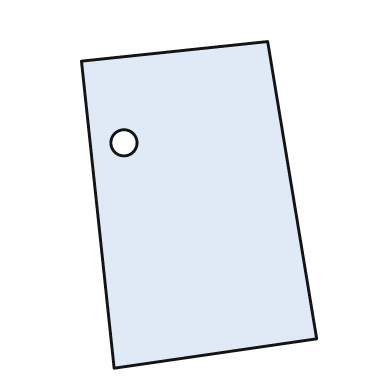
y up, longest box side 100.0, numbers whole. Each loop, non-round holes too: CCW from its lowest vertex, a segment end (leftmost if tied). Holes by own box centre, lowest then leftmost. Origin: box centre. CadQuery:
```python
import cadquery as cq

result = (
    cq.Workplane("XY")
    .moveTo(-26.0, -50.0)
    .lineTo(36.0, -41.0)
    .lineTo(21.0, 50.0)
    .lineTo(-36.0, 44.0)
    .close()
    .moveTo(-23.0, 19.0)
    .circle(4.0)
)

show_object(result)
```